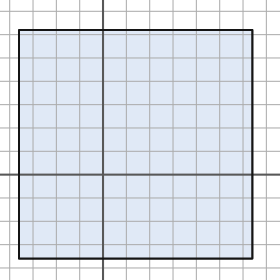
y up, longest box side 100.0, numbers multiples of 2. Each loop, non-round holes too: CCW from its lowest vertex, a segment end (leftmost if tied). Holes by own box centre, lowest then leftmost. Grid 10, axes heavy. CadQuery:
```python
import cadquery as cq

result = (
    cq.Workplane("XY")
    .moveTo(-36.0, -36.0)
    .lineTo(64.0, -36.0)
    .lineTo(64.0, 62.0)
    .lineTo(-36.0, 62.0)
    .close()
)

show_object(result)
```